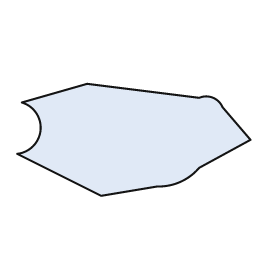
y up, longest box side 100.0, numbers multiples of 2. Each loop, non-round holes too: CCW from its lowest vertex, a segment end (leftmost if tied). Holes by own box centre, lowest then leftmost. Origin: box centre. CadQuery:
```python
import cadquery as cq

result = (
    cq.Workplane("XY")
    .moveTo(-14.0, -24.0)
    .lineTo(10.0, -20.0)
    .threePointArc((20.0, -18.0), (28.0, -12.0))
    .lineTo(50.0, 0.0)
    .lineTo(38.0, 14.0)
    .threePointArc((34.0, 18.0), (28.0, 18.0))
    .lineTo(-20.0, 24.0)
    .lineTo(-48.0, 16.0)
    .threePointArc((-40.0, 4.0), (-50.0, -6.0))
    .close()
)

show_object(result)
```